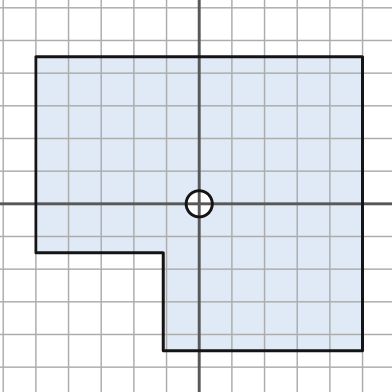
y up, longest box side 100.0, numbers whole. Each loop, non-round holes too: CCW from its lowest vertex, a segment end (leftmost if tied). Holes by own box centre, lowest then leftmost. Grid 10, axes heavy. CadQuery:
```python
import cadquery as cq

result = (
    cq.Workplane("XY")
    .moveTo(-11.0, -45.0)
    .lineTo(50.0, -45.0)
    .lineTo(50.0, 45.0)
    .lineTo(-50.0, 45.0)
    .lineTo(-50.0, -15.0)
    .lineTo(-11.0, -15.0)
    .close()
    .moveTo(0.0, 0.0)
    .circle(4.0)
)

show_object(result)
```